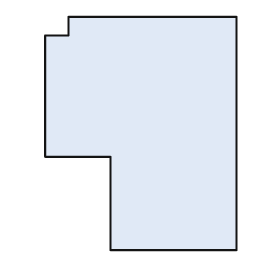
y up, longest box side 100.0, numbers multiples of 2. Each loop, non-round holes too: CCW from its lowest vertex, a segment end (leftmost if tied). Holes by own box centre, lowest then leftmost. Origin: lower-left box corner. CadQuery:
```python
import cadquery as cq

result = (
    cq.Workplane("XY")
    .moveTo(28.0, 0.0)
    .lineTo(82.0, 0.0)
    .lineTo(82.0, 100.0)
    .lineTo(10.0, 100.0)
    .lineTo(10.0, 92.0)
    .lineTo(0.0, 92.0)
    .lineTo(0.0, 40.0)
    .lineTo(28.0, 40.0)
    .close()
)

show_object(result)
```